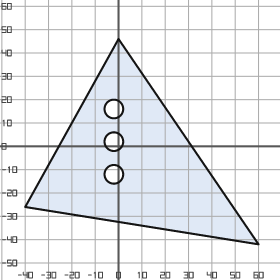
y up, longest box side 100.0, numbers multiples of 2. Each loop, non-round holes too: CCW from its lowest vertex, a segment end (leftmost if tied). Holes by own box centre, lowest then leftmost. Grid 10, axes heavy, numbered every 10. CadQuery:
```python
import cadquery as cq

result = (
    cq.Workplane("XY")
    .moveTo(60.0, -42.0)
    .lineTo(0.0, 46.0)
    .lineTo(-40.0, -26.0)
    .close()
    .moveTo(-2.0, -12.0)
    .circle(4.0)
    .moveTo(-2.0, 2.0)
    .circle(4.0)
    .moveTo(-2.0, 16.0)
    .circle(4.0)
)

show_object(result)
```